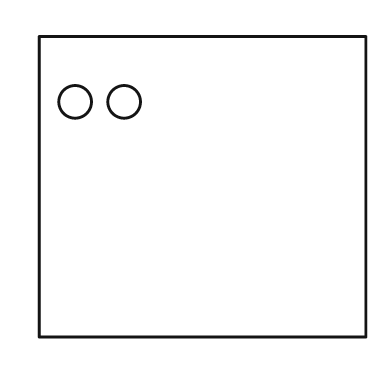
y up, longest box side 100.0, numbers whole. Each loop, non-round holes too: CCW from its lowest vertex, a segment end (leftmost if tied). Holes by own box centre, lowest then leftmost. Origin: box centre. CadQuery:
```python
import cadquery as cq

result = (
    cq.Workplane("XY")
    .moveTo(-50.0, -46.0)
    .lineTo(50.0, -46.0)
    .lineTo(50.0, 46.0)
    .lineTo(-50.0, 46.0)
    .close()
    .moveTo(-39.0, 26.0)
    .circle(5.0)
    .moveTo(-24.0, 26.0)
    .circle(5.0)
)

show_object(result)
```